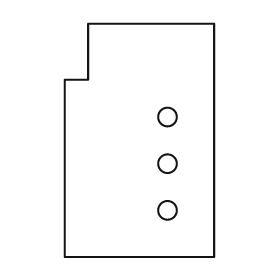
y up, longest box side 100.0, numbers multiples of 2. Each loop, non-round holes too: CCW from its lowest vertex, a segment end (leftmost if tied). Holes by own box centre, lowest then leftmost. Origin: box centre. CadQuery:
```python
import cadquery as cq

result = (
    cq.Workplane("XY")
    .moveTo(-32.0, -50.0)
    .lineTo(32.0, -50.0)
    .lineTo(32.0, 50.0)
    .lineTo(-22.0, 50.0)
    .lineTo(-22.0, 26.0)
    .lineTo(-32.0, 26.0)
    .close()
    .moveTo(12.0, -30.0)
    .circle(4.0)
    .moveTo(12.0, -10.0)
    .circle(4.0)
    .moveTo(12.0, 10.0)
    .circle(4.0)
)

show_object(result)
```